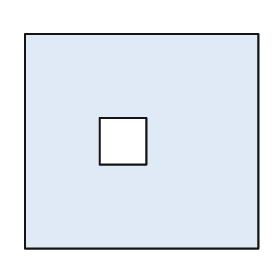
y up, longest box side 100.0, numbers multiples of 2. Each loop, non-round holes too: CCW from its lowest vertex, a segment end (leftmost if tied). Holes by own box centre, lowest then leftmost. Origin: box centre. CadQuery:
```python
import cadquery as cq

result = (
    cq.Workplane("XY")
    .moveTo(-50.0, -46.0)
    .lineTo(50.0, -46.0)
    .lineTo(50.0, 46.0)
    .lineTo(-50.0, 46.0)
    .close()
    .moveTo(-18.0, -10.0)
    .lineTo(2.0, -10.0)
    .lineTo(2.0, 10.0)
    .lineTo(-18.0, 10.0)
    .close()
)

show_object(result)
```